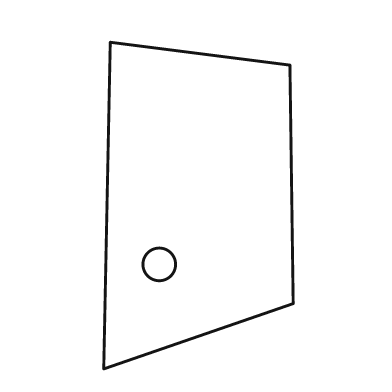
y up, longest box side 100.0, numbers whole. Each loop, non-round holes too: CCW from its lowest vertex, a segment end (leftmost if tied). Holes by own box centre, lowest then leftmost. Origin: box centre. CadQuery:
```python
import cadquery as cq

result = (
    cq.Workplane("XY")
    .moveTo(-29.0, -50.0)
    .lineTo(29.0, -30.0)
    .lineTo(28.0, 43.0)
    .lineTo(-27.0, 50.0)
    .close()
    .moveTo(-12.0, -18.0)
    .circle(5.0)
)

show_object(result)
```